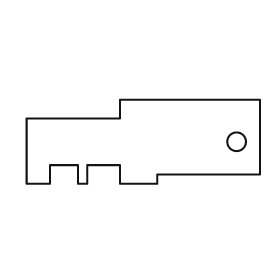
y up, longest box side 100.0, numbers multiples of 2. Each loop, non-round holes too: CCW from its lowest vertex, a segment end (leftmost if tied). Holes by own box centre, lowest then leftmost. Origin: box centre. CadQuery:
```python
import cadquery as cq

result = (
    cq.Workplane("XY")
    .moveTo(-50.0, -18.0)
    .lineTo(-40.0, -18.0)
    .lineTo(-40.0, -10.0)
    .lineTo(-28.0, -10.0)
    .lineTo(-28.0, -18.0)
    .lineTo(-24.0, -18.0)
    .lineTo(-24.0, -10.0)
    .lineTo(-10.0, -10.0)
    .lineTo(-10.0, -18.0)
    .lineTo(6.0, -18.0)
    .lineTo(6.0, -14.0)
    .lineTo(50.0, -14.0)
    .lineTo(50.0, 18.0)
    .lineTo(-10.0, 18.0)
    .lineTo(-10.0, 10.0)
    .lineTo(-50.0, 10.0)
    .close()
    .moveTo(40.0, 0.0)
    .circle(4.0)
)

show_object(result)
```